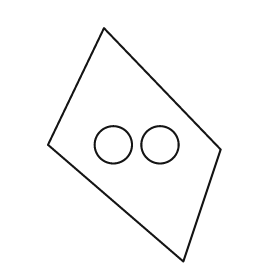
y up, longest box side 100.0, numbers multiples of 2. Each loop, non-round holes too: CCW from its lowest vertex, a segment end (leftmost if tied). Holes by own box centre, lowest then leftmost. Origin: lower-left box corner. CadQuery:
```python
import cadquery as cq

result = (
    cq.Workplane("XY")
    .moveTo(58.0, 0.0)
    .lineTo(74.0, 48.0)
    .lineTo(24.0, 100.0)
    .lineTo(0.0, 50.0)
    .close()
    .moveTo(28.0, 50.0)
    .circle(8.0)
    .moveTo(48.0, 50.0)
    .circle(8.0)
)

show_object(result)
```